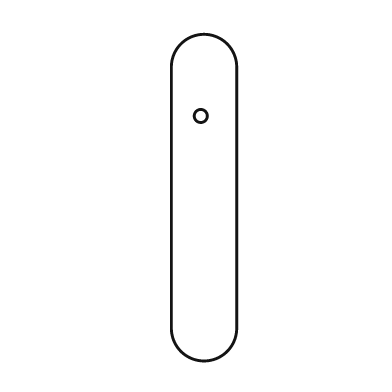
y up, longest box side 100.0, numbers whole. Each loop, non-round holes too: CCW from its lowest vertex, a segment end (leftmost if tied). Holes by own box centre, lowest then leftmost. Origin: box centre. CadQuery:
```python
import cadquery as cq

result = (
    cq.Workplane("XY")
    .moveTo(-10.0, -40.0)
    .threePointArc((0.0, -50.0), (10.0, -40.0))
    .lineTo(10.0, 40.0)
    .threePointArc((0.0, 50.0), (-10.0, 40.0))
    .close()
    .moveTo(-1.0, 25.0)
    .circle(2.0)
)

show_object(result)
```